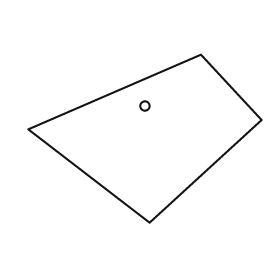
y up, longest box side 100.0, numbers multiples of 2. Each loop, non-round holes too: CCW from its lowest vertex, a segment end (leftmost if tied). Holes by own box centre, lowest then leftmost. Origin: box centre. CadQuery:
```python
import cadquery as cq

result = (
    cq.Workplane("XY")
    .moveTo(2.0, -36.0)
    .lineTo(50.0, 8.0)
    .lineTo(24.0, 36.0)
    .lineTo(-50.0, 4.0)
    .close()
    .moveTo(0.0, 14.0)
    .circle(2.0)
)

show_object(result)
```